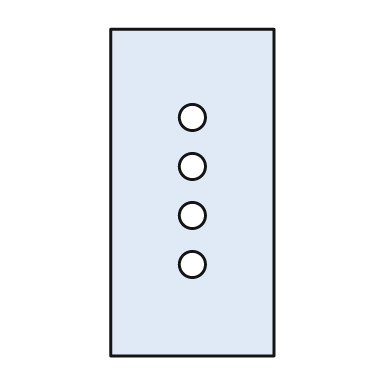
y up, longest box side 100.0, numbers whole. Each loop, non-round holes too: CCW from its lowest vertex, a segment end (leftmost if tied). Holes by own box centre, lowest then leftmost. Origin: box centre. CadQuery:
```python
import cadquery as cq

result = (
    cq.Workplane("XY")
    .moveTo(-25.0, -50.0)
    .lineTo(25.0, -50.0)
    .lineTo(25.0, 50.0)
    .lineTo(-25.0, 50.0)
    .close()
    .moveTo(0.0, -22.0)
    .circle(4.0)
    .moveTo(0.0, -7.0)
    .circle(4.0)
    .moveTo(0.0, 8.0)
    .circle(4.0)
    .moveTo(0.0, 23.0)
    .circle(4.0)
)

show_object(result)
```